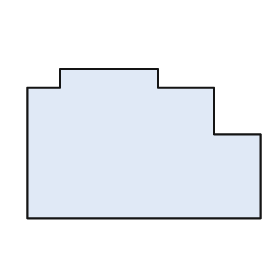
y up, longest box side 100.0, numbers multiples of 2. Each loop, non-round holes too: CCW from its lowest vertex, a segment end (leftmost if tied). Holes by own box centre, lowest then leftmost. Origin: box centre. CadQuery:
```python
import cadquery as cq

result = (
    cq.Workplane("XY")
    .moveTo(-50.0, -32.0)
    .lineTo(50.0, -32.0)
    .lineTo(50.0, 4.0)
    .lineTo(30.0, 4.0)
    .lineTo(30.0, 24.0)
    .lineTo(6.0, 24.0)
    .lineTo(6.0, 32.0)
    .lineTo(-36.0, 32.0)
    .lineTo(-36.0, 24.0)
    .lineTo(-50.0, 24.0)
    .close()
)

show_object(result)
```